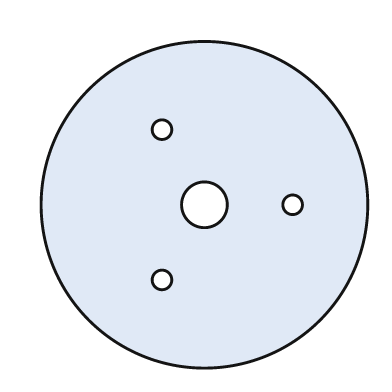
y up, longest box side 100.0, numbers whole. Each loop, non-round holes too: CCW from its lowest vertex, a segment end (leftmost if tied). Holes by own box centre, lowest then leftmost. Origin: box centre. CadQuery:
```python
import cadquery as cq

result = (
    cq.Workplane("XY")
    .moveTo(0.0, 0.0)
    .circle(50.0)
    .moveTo(-13.0, -23.0)
    .circle(3.0)
    .moveTo(0.0, 0.0)
    .circle(7.0)
    .moveTo(27.0, 0.0)
    .circle(3.0)
    .moveTo(-13.0, 23.0)
    .circle(3.0)
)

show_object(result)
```